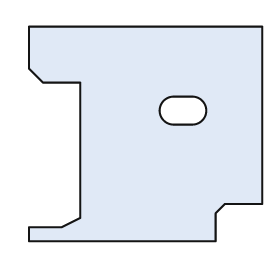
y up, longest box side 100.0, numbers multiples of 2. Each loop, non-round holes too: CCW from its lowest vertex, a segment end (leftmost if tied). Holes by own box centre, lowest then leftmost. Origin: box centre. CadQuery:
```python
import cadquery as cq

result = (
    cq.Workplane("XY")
    .moveTo(-50.0, -46.0)
    .lineTo(30.0, -46.0)
    .lineTo(30.0, -34.0)
    .lineTo(34.0, -30.0)
    .lineTo(50.0, -30.0)
    .lineTo(50.0, 46.0)
    .lineTo(-50.0, 46.0)
    .lineTo(-50.0, 28.0)
    .lineTo(-44.0, 22.0)
    .lineTo(-28.0, 22.0)
    .lineTo(-28.0, -36.0)
    .lineTo(-36.0, -40.0)
    .lineTo(-50.0, -40.0)
    .close()
    .moveTo(12.0, 4.0)
    .lineTo(20.0, 4.0)
    .threePointArc((26.0, 10.0), (20.0, 16.0))
    .lineTo(12.0, 16.0)
    .threePointArc((6.0, 10.0), (12.0, 4.0))
    .close()
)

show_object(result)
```